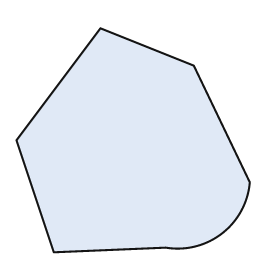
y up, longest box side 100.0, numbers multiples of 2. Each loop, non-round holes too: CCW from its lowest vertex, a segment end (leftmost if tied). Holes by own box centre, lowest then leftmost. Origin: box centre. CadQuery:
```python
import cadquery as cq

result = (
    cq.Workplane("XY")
    .moveTo(-34.0, -48.0)
    .lineTo(14.0, -46.0)
    .threePointArc((38.0, -40.0), (50.0, -18.0))
    .lineTo(26.0, 32.0)
    .lineTo(-14.0, 48.0)
    .lineTo(-50.0, 0.0)
    .close()
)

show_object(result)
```